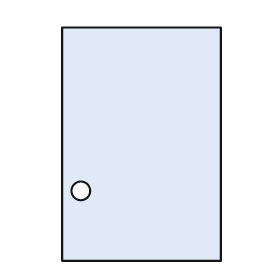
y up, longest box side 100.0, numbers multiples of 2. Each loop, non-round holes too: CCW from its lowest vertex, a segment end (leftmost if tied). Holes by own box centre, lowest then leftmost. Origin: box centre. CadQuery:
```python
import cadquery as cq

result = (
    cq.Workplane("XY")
    .moveTo(-34.0, -50.0)
    .lineTo(34.0, -50.0)
    .lineTo(34.0, 50.0)
    .lineTo(-34.0, 50.0)
    .close()
    .moveTo(-26.0, -20.0)
    .circle(4.0)
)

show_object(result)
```